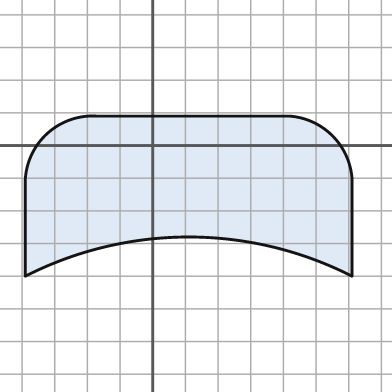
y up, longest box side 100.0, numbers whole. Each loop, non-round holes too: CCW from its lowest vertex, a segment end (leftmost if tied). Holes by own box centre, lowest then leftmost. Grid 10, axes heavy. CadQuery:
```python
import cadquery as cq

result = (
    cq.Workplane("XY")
    .moveTo(-39.0, -40.0)
    .threePointArc((11.0, -28.0), (61.0, -40.0))
    .lineTo(61.0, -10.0)
    .threePointArc((55.0, 3.0), (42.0, 9.0))
    .lineTo(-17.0, 9.0)
    .threePointArc((-33.0, 3.0), (-39.0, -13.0))
    .close()
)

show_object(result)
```